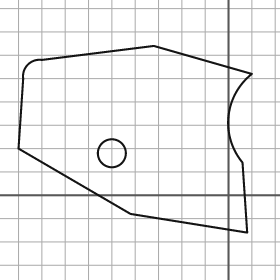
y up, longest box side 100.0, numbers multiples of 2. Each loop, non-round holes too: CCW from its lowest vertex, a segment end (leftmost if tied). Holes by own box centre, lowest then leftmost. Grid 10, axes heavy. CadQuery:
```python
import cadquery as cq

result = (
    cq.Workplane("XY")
    .moveTo(8.0, -16.0)
    .lineTo(6.0, 14.0)
    .threePointArc((0.0, 34.0), (10.0, 52.0))
    .lineTo(-32.0, 64.0)
    .lineTo(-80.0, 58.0)
    .threePointArc((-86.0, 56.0), (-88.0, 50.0))
    .lineTo(-90.0, 20.0)
    .lineTo(-42.0, -8.0)
    .close()
    .moveTo(-50.0, 18.0)
    .circle(6.0)
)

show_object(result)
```